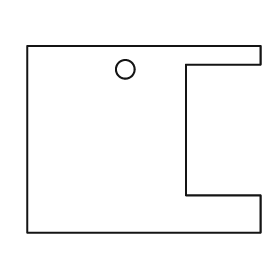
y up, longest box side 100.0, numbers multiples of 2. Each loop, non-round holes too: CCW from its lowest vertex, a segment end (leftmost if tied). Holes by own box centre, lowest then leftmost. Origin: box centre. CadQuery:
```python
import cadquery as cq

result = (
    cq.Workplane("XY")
    .moveTo(-50.0, -40.0)
    .lineTo(50.0, -40.0)
    .lineTo(50.0, -24.0)
    .lineTo(18.0, -24.0)
    .lineTo(18.0, 32.0)
    .lineTo(50.0, 32.0)
    .lineTo(50.0, 40.0)
    .lineTo(-50.0, 40.0)
    .close()
    .moveTo(-8.0, 30.0)
    .circle(4.0)
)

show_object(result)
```